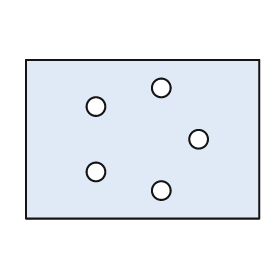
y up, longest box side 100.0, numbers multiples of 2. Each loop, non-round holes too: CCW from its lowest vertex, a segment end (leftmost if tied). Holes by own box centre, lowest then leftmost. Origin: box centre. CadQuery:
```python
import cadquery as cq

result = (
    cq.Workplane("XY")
    .moveTo(-50.0, -34.0)
    .lineTo(50.0, -34.0)
    .lineTo(50.0, 34.0)
    .lineTo(-50.0, 34.0)
    .close()
    .moveTo(8.0, -22.0)
    .circle(4.0)
    .moveTo(-20.0, -14.0)
    .circle(4.0)
    .moveTo(24.0, 0.0)
    .circle(4.0)
    .moveTo(-20.0, 14.0)
    .circle(4.0)
    .moveTo(8.0, 22.0)
    .circle(4.0)
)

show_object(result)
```